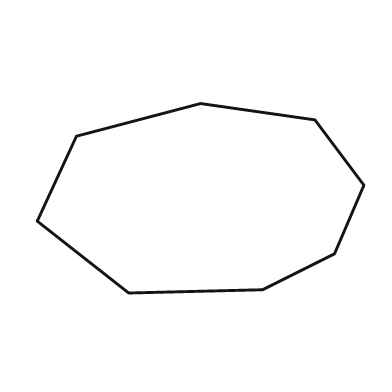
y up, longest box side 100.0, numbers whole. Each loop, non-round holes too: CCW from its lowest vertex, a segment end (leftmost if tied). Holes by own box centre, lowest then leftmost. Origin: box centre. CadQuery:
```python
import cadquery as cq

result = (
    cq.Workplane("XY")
    .moveTo(-22.0, -29.0)
    .lineTo(19.0, -28.0)
    .lineTo(41.0, -17.0)
    .lineTo(50.0, 4.0)
    .lineTo(35.0, 24.0)
    .lineTo(0.0, 29.0)
    .lineTo(-38.0, 19.0)
    .lineTo(-50.0, -7.0)
    .close()
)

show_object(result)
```